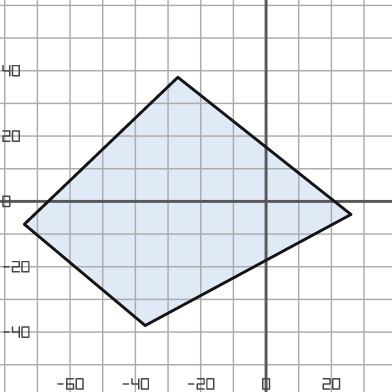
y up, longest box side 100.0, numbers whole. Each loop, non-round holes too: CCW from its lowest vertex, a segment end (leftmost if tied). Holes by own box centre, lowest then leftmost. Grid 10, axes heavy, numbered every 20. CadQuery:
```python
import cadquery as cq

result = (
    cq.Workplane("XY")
    .moveTo(-37.0, -38.0)
    .lineTo(26.0, -4.0)
    .lineTo(-27.0, 38.0)
    .lineTo(-74.0, -7.0)
    .close()
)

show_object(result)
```